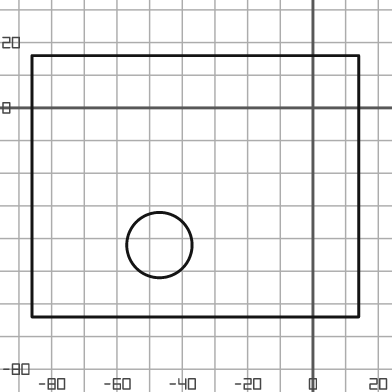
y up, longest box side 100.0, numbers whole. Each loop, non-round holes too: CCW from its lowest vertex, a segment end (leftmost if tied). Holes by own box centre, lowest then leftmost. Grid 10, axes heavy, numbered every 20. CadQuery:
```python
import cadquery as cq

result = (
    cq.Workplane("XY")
    .moveTo(-86.0, -64.0)
    .lineTo(14.0, -64.0)
    .lineTo(14.0, 16.0)
    .lineTo(-86.0, 16.0)
    .close()
    .moveTo(-47.0, -42.0)
    .circle(10.0)
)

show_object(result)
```